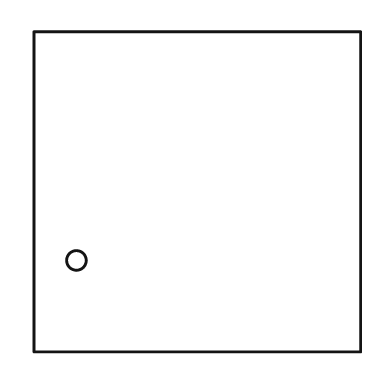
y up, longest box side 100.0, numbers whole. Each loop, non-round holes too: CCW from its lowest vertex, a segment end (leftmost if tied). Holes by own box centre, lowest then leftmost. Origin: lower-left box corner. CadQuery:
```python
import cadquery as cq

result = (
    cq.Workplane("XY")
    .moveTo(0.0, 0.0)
    .lineTo(100.0, 0.0)
    .lineTo(100.0, 98.0)
    .lineTo(0.0, 98.0)
    .close()
    .moveTo(13.0, 28.0)
    .circle(3.0)
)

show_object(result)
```